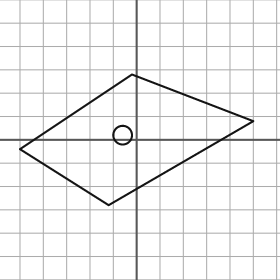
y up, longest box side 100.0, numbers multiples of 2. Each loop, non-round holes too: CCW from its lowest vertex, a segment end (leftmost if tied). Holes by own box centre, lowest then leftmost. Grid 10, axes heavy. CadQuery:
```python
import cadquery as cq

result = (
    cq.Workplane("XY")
    .moveTo(-12.0, -28.0)
    .lineTo(50.0, 8.0)
    .lineTo(-2.0, 28.0)
    .lineTo(-50.0, -4.0)
    .close()
    .moveTo(-6.0, 2.0)
    .circle(4.0)
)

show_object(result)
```